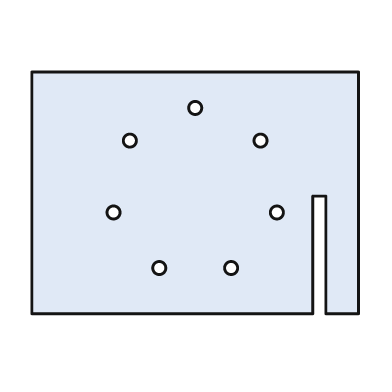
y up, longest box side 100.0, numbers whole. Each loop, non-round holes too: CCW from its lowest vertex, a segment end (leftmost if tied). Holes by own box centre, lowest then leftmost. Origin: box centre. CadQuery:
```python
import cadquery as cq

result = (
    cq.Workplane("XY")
    .moveTo(-50.0, -37.0)
    .lineTo(36.0, -37.0)
    .lineTo(36.0, -1.0)
    .lineTo(40.0, -1.0)
    .lineTo(40.0, -37.0)
    .lineTo(50.0, -37.0)
    .lineTo(50.0, 37.0)
    .lineTo(-50.0, 37.0)
    .close()
    .moveTo(-11.0, -23.0)
    .circle(2.0)
    .moveTo(11.0, -23.0)
    .circle(2.0)
    .moveTo(-25.0, -6.0)
    .circle(2.0)
    .moveTo(25.0, -6.0)
    .circle(2.0)
    .moveTo(-20.0, 16.0)
    .circle(2.0)
    .moveTo(20.0, 16.0)
    .circle(2.0)
    .moveTo(0.0, 26.0)
    .circle(2.0)
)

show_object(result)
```